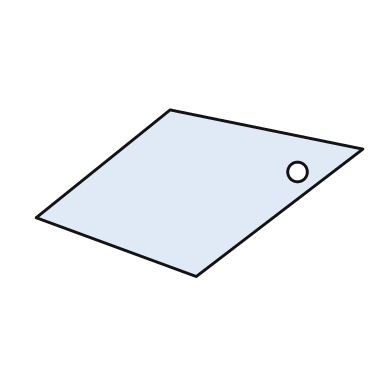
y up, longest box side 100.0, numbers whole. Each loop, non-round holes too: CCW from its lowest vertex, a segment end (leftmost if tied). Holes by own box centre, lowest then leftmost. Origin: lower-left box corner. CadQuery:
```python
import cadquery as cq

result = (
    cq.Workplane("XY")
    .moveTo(49.0, 0.0)
    .lineTo(100.0, 39.0)
    .lineTo(41.0, 51.0)
    .lineTo(0.0, 18.0)
    .close()
    .moveTo(80.0, 32.0)
    .circle(3.0)
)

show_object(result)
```